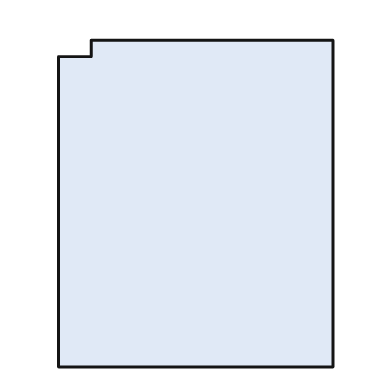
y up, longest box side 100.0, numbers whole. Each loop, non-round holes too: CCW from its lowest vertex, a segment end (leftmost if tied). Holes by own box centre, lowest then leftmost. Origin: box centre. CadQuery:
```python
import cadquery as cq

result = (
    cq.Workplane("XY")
    .moveTo(-42.0, -50.0)
    .lineTo(42.0, -50.0)
    .lineTo(42.0, 50.0)
    .lineTo(-32.0, 50.0)
    .lineTo(-32.0, 45.0)
    .lineTo(-42.0, 45.0)
    .close()
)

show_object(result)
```